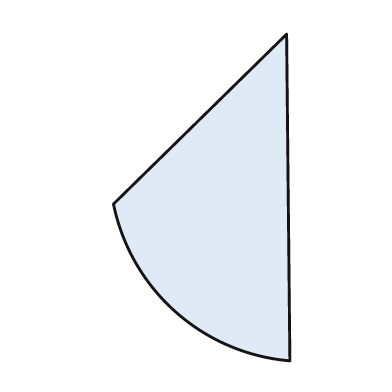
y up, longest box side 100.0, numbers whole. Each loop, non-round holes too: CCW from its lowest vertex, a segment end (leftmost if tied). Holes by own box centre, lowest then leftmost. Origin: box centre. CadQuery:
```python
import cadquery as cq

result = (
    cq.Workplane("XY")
    .moveTo(27.0, -50.0)
    .lineTo(26.0, 50.0)
    .lineTo(-27.0, -2.0)
    .threePointArc((-8.0, -35.0), (27.0, -50.0))
    .close()
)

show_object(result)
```